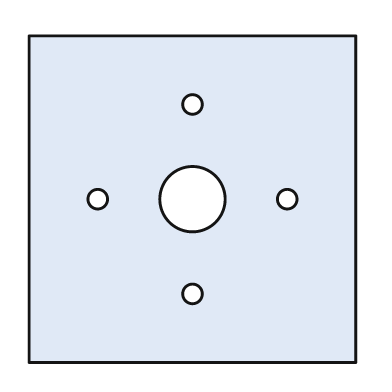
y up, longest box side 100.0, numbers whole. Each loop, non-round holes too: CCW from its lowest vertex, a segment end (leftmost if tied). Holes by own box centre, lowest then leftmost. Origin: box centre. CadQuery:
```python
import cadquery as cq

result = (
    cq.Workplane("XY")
    .moveTo(-50.0, -50.0)
    .lineTo(50.0, -50.0)
    .lineTo(50.0, 50.0)
    .lineTo(-50.0, 50.0)
    .close()
    .moveTo(0.0, -29.0)
    .circle(3.0)
    .moveTo(-29.0, 0.0)
    .circle(3.0)
    .moveTo(0.0, 0.0)
    .circle(10.0)
    .moveTo(29.0, 0.0)
    .circle(3.0)
    .moveTo(0.0, 29.0)
    .circle(3.0)
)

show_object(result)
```